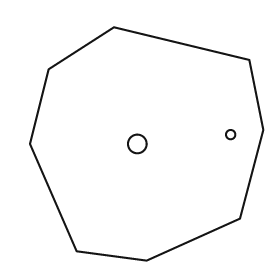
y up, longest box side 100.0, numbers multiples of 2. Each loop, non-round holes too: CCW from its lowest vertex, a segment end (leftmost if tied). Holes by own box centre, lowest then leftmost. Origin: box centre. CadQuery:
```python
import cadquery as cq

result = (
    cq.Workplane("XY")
    .moveTo(0.0, -50.0)
    .lineTo(40.0, -32.0)
    .lineTo(50.0, 6.0)
    .lineTo(44.0, 36.0)
    .lineTo(-14.0, 50.0)
    .lineTo(-42.0, 32.0)
    .lineTo(-50.0, 0.0)
    .lineTo(-30.0, -46.0)
    .close()
    .moveTo(-4.0, 0.0)
    .circle(4.0)
    .moveTo(36.0, 4.0)
    .circle(2.0)
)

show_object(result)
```